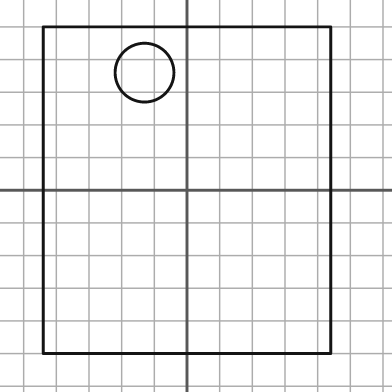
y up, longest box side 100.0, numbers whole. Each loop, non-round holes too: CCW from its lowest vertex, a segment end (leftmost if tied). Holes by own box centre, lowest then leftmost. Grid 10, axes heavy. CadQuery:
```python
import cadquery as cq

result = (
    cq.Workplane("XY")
    .moveTo(-44.0, -50.0)
    .lineTo(44.0, -50.0)
    .lineTo(44.0, 50.0)
    .lineTo(-44.0, 50.0)
    .close()
    .moveTo(-13.0, 36.0)
    .circle(9.0)
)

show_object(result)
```